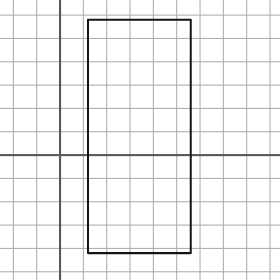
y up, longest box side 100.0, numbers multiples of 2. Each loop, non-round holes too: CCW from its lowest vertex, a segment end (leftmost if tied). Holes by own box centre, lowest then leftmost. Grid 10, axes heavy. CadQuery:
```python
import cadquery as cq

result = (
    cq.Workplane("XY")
    .moveTo(12.0, -42.0)
    .lineTo(56.0, -42.0)
    .lineTo(56.0, 58.0)
    .lineTo(12.0, 58.0)
    .close()
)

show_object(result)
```